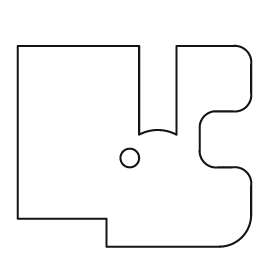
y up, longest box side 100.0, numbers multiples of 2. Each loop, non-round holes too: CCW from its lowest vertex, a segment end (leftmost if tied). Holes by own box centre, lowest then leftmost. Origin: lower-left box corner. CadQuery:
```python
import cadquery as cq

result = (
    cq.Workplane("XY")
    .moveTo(38.0, 0.0)
    .lineTo(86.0, 0.0)
    .threePointArc((96.0, 4.0), (100.0, 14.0))
    .lineTo(100.0, 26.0)
    .threePointArc((98.0, 32.0), (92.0, 34.0))
    .lineTo(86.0, 34.0)
    .threePointArc((80.0, 36.0), (78.0, 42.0))
    .lineTo(78.0, 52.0)
    .threePointArc((80.0, 56.0), (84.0, 58.0))
    .lineTo(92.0, 58.0)
    .threePointArc((98.0, 60.0), (100.0, 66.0))
    .lineTo(100.0, 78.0)
    .threePointArc((98.0, 84.0), (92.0, 86.0))
    .lineTo(68.0, 86.0)
    .lineTo(68.0, 48.0)
    .threePointArc((60.0, 50.0), (52.0, 48.0))
    .lineTo(52.0, 86.0)
    .lineTo(0.0, 86.0)
    .lineTo(0.0, 12.0)
    .lineTo(38.0, 12.0)
    .close()
    .moveTo(48.0, 38.0)
    .circle(4.0)
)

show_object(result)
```